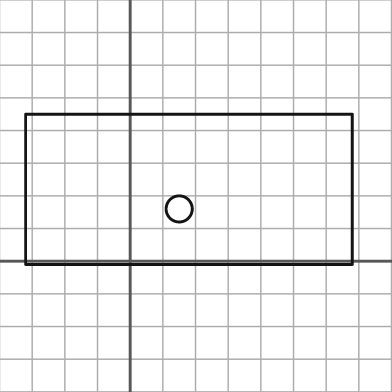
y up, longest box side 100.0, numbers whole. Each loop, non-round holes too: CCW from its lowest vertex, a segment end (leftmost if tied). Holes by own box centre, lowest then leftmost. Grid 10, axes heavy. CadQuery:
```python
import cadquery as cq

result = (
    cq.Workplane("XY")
    .moveTo(-32.0, -1.0)
    .lineTo(68.0, -1.0)
    .lineTo(68.0, 45.0)
    .lineTo(-32.0, 45.0)
    .close()
    .moveTo(15.0, 16.0)
    .circle(4.0)
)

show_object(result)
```